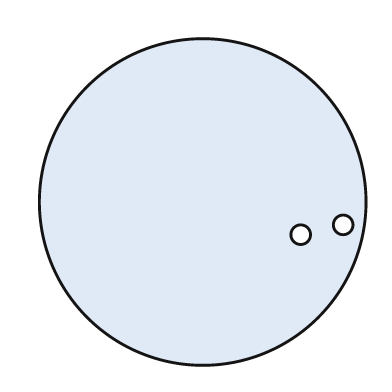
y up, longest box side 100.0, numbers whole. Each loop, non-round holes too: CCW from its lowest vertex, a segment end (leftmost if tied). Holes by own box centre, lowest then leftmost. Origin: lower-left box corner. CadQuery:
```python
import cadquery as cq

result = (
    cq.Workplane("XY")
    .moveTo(50.0, 50.0)
    .circle(50.0)
    .moveTo(80.0, 40.0)
    .circle(3.0)
    .moveTo(93.0, 43.0)
    .circle(3.0)
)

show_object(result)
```